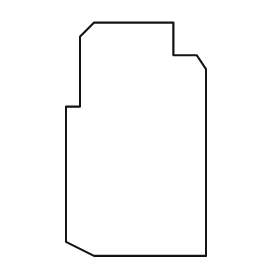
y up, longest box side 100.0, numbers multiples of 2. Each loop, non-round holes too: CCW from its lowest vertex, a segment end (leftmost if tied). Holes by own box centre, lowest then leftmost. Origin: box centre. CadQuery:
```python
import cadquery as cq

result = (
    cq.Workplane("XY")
    .moveTo(-18.0, -50.0)
    .lineTo(30.0, -50.0)
    .lineTo(30.0, 30.0)
    .lineTo(26.0, 36.0)
    .lineTo(16.0, 36.0)
    .lineTo(16.0, 50.0)
    .lineTo(-18.0, 50.0)
    .lineTo(-24.0, 44.0)
    .lineTo(-24.0, 14.0)
    .lineTo(-30.0, 14.0)
    .lineTo(-30.0, -44.0)
    .close()
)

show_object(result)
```